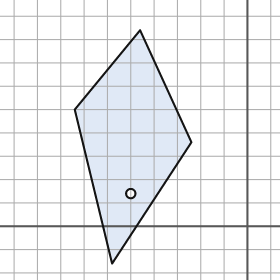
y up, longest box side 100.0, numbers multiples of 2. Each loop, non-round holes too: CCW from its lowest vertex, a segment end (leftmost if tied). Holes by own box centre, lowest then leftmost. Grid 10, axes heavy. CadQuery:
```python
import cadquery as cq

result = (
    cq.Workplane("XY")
    .moveTo(-58.0, -16.0)
    .lineTo(-24.0, 36.0)
    .lineTo(-46.0, 84.0)
    .lineTo(-74.0, 50.0)
    .close()
    .moveTo(-50.0, 14.0)
    .circle(2.0)
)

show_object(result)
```